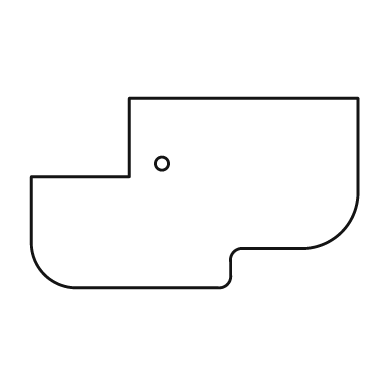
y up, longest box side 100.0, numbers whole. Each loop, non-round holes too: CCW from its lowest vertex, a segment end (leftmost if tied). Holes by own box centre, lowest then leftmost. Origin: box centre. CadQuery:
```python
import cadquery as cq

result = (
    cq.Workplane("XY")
    .moveTo(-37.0, -29.0)
    .lineTo(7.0, -29.0)
    .threePointArc((10.0, -28.0), (11.0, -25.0))
    .lineTo(11.0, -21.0)
    .threePointArc((12.0, -18.0), (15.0, -17.0))
    .lineTo(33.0, -17.0)
    .threePointArc((45.0, -12.0), (50.0, 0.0))
    .lineTo(50.0, 29.0)
    .lineTo(-20.0, 29.0)
    .lineTo(-20.0, 5.0)
    .lineTo(-50.0, 5.0)
    .lineTo(-50.0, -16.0)
    .threePointArc((-46.0, -25.0), (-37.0, -29.0))
    .close()
    .moveTo(-10.0, 9.0)
    .circle(2.0)
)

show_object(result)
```